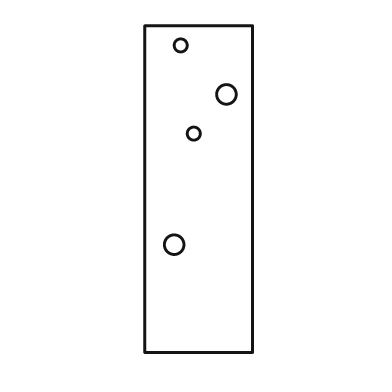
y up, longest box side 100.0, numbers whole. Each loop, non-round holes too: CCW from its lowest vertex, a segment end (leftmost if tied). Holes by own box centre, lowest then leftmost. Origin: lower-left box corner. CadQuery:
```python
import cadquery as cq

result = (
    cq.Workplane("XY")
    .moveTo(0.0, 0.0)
    .lineTo(33.0, 0.0)
    .lineTo(33.0, 100.0)
    .lineTo(0.0, 100.0)
    .close()
    .moveTo(9.0, 33.0)
    .circle(3.0)
    .moveTo(15.0, 67.0)
    .circle(2.0)
    .moveTo(25.0, 79.0)
    .circle(3.0)
    .moveTo(11.0, 94.0)
    .circle(2.0)
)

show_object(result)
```